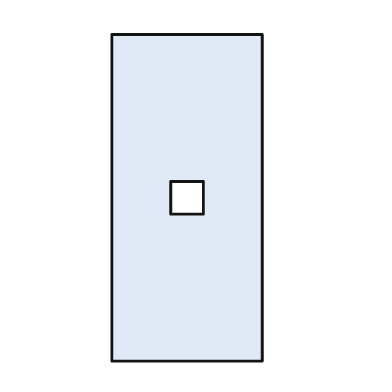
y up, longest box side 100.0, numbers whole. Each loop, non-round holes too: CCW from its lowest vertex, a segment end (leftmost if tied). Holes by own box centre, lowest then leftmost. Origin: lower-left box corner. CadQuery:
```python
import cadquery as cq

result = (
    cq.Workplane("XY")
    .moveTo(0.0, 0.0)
    .lineTo(46.0, 0.0)
    .lineTo(46.0, 100.0)
    .lineTo(0.0, 100.0)
    .close()
    .moveTo(18.0, 45.0)
    .lineTo(28.0, 45.0)
    .lineTo(28.0, 55.0)
    .lineTo(18.0, 55.0)
    .close()
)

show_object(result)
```